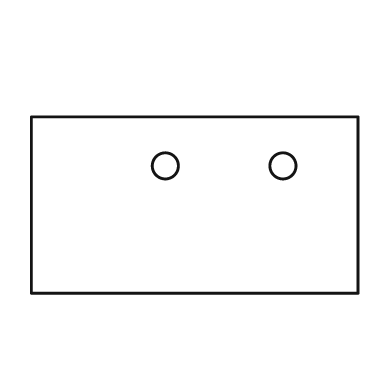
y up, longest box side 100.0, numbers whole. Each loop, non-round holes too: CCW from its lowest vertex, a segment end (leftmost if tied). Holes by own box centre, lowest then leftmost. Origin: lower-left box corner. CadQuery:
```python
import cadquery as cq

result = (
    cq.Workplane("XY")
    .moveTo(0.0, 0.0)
    .lineTo(100.0, 0.0)
    .lineTo(100.0, 54.0)
    .lineTo(0.0, 54.0)
    .close()
    .moveTo(41.0, 39.0)
    .circle(4.0)
    .moveTo(77.0, 39.0)
    .circle(4.0)
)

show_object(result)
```